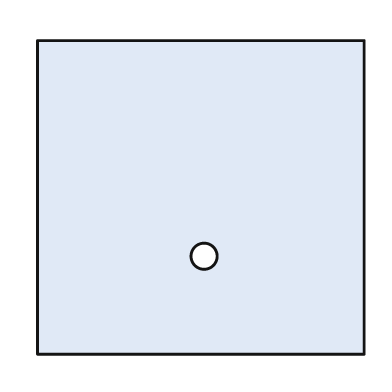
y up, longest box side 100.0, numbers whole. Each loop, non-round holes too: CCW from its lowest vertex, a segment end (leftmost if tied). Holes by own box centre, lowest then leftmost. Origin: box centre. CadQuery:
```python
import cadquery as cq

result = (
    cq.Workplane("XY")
    .moveTo(-50.0, -48.0)
    .lineTo(50.0, -48.0)
    .lineTo(50.0, 48.0)
    .lineTo(-50.0, 48.0)
    .close()
    .moveTo(1.0, -18.0)
    .circle(4.0)
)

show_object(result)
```